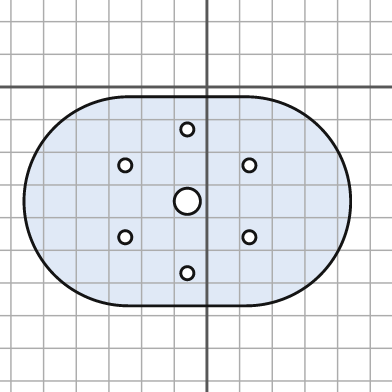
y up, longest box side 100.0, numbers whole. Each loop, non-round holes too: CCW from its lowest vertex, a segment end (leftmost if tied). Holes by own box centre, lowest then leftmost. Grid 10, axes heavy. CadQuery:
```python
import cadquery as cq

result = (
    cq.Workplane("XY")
    .moveTo(-24.0, -67.0)
    .lineTo(12.0, -67.0)
    .threePointArc((44.0, -35.0), (12.0, -3.0))
    .lineTo(-24.0, -3.0)
    .threePointArc((-56.0, -35.0), (-24.0, -67.0))
    .close()
    .moveTo(-6.0, -57.0)
    .circle(2.0)
    .moveTo(-25.0, -46.0)
    .circle(2.0)
    .moveTo(13.0, -46.0)
    .circle(2.0)
    .moveTo(-6.0, -35.0)
    .circle(4.0)
    .moveTo(-25.0, -24.0)
    .circle(2.0)
    .moveTo(13.0, -24.0)
    .circle(2.0)
    .moveTo(-6.0, -13.0)
    .circle(2.0)
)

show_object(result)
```